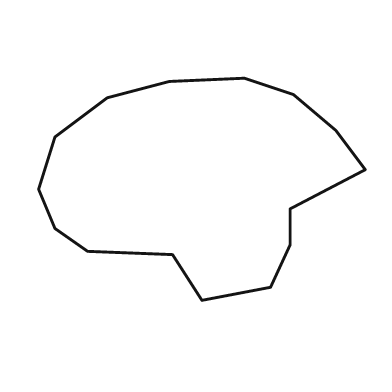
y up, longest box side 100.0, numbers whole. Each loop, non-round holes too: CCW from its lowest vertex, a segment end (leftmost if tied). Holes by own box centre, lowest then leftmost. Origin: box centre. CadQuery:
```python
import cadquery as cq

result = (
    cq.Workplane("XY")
    .moveTo(0.0, -34.0)
    .lineTo(21.0, -30.0)
    .lineTo(27.0, -17.0)
    .lineTo(27.0, -6.0)
    .lineTo(50.0, 6.0)
    .lineTo(41.0, 18.0)
    .lineTo(28.0, 29.0)
    .lineTo(13.0, 34.0)
    .lineTo(-10.0, 33.0)
    .lineTo(-29.0, 28.0)
    .lineTo(-45.0, 16.0)
    .lineTo(-50.0, 0.0)
    .lineTo(-45.0, -12.0)
    .lineTo(-35.0, -19.0)
    .lineTo(-9.0, -20.0)
    .close()
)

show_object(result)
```